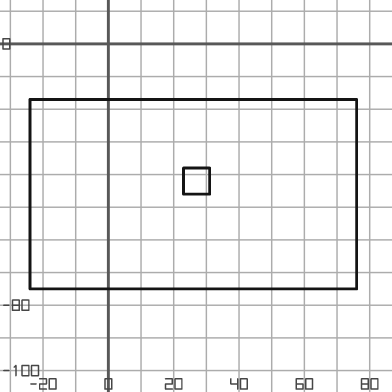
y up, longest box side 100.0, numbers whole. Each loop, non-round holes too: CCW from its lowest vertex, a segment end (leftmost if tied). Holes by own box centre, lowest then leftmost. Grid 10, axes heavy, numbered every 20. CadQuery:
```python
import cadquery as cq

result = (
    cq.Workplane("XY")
    .moveTo(-24.0, -75.0)
    .lineTo(76.0, -75.0)
    .lineTo(76.0, -17.0)
    .lineTo(-24.0, -17.0)
    .close()
    .moveTo(23.0, -46.0)
    .lineTo(31.0, -46.0)
    .lineTo(31.0, -38.0)
    .lineTo(23.0, -38.0)
    .close()
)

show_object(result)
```